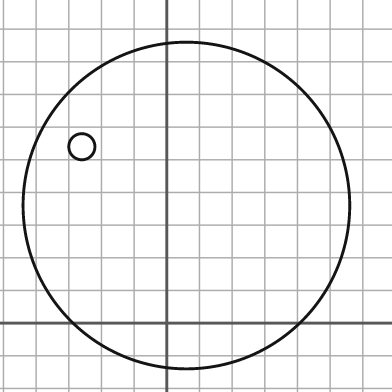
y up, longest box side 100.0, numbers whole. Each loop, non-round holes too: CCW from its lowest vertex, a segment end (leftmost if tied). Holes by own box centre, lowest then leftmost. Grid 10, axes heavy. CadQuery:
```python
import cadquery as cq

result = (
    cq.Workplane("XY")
    .moveTo(6.0, 36.0)
    .circle(50.0)
    .moveTo(-26.0, 54.0)
    .circle(4.0)
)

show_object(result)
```